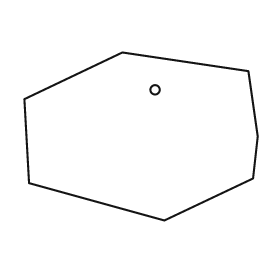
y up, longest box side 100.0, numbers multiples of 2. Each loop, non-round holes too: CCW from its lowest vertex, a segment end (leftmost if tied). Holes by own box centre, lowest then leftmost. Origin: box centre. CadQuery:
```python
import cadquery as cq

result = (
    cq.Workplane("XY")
    .moveTo(10.0, -36.0)
    .lineTo(48.0, -18.0)
    .lineTo(50.0, 0.0)
    .lineTo(46.0, 28.0)
    .lineTo(-8.0, 36.0)
    .lineTo(-50.0, 16.0)
    .lineTo(-48.0, -20.0)
    .close()
    .moveTo(6.0, 20.0)
    .circle(2.0)
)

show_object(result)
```